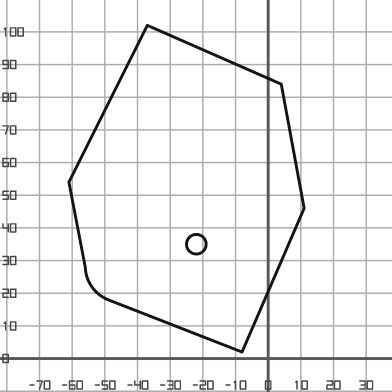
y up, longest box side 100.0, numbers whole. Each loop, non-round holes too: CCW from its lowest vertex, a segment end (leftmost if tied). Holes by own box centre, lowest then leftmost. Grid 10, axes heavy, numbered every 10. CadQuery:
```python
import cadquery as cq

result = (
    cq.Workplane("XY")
    .moveTo(-8.0, 2.0)
    .lineTo(11.0, 46.0)
    .lineTo(4.0, 84.0)
    .lineTo(-37.0, 102.0)
    .lineTo(-61.0, 54.0)
    .lineTo(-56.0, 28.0)
    .threePointArc((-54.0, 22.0), (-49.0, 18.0))
    .close()
    .moveTo(-22.0, 35.0)
    .circle(3.0)
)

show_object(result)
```